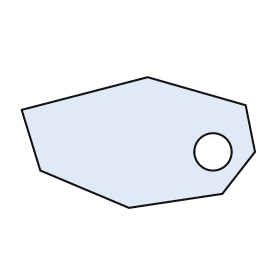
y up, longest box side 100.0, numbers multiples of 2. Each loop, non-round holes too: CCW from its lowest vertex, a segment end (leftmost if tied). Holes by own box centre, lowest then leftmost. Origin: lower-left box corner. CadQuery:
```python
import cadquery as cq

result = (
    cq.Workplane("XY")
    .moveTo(46.0, 0.0)
    .lineTo(86.0, 6.0)
    .lineTo(100.0, 24.0)
    .lineTo(96.0, 44.0)
    .lineTo(54.0, 56.0)
    .lineTo(0.0, 42.0)
    .lineTo(8.0, 16.0)
    .close()
    .moveTo(82.0, 24.0)
    .circle(8.0)
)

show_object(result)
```